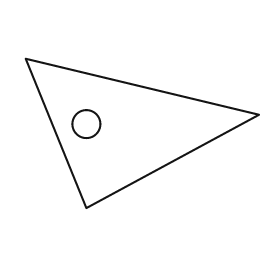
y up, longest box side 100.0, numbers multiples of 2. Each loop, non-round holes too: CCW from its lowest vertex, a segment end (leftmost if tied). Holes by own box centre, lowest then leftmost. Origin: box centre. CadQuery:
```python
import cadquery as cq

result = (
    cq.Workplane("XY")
    .moveTo(-24.0, -32.0)
    .lineTo(50.0, 8.0)
    .lineTo(-50.0, 32.0)
    .close()
    .moveTo(-24.0, 4.0)
    .circle(6.0)
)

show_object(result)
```